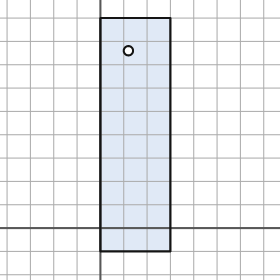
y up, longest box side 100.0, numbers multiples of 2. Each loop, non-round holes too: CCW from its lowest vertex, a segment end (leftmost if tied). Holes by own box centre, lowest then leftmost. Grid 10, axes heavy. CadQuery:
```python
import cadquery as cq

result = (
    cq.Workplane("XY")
    .moveTo(0.0, -10.0)
    .lineTo(30.0, -10.0)
    .lineTo(30.0, 90.0)
    .lineTo(0.0, 90.0)
    .close()
    .moveTo(12.0, 76.0)
    .circle(2.0)
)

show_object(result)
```